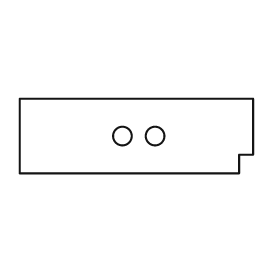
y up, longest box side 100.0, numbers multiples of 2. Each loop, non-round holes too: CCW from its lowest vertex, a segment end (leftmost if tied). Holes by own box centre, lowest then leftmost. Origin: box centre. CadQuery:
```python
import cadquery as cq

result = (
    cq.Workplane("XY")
    .moveTo(-50.0, -16.0)
    .lineTo(44.0, -16.0)
    .lineTo(44.0, -8.0)
    .lineTo(50.0, -8.0)
    .lineTo(50.0, 16.0)
    .lineTo(-50.0, 16.0)
    .close()
    .moveTo(-6.0, 0.0)
    .circle(4.0)
    .moveTo(8.0, 0.0)
    .circle(4.0)
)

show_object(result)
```